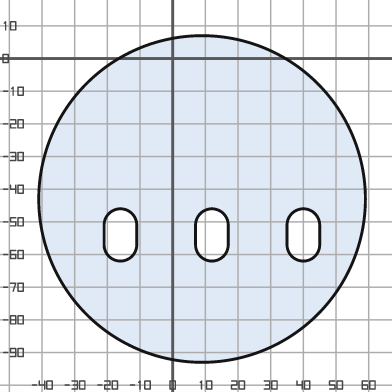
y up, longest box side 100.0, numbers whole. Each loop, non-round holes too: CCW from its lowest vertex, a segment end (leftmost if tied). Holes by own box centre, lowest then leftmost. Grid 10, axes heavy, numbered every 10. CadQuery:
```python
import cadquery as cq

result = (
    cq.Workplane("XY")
    .moveTo(9.0, -43.0)
    .circle(50.0)
    .moveTo(-21.0, -57.0)
    .threePointArc((-16.0, -62.0), (-11.0, -57.0))
    .lineTo(-11.0, -51.0)
    .threePointArc((-16.0, -46.0), (-21.0, -51.0))
    .close()
    .moveTo(7.0, -57.0)
    .threePointArc((12.0, -62.0), (17.0, -57.0))
    .lineTo(17.0, -51.0)
    .threePointArc((12.0, -46.0), (7.0, -51.0))
    .close()
    .moveTo(35.0, -57.0)
    .threePointArc((40.0, -62.0), (45.0, -57.0))
    .lineTo(45.0, -51.0)
    .threePointArc((40.0, -46.0), (35.0, -51.0))
    .close()
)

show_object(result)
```